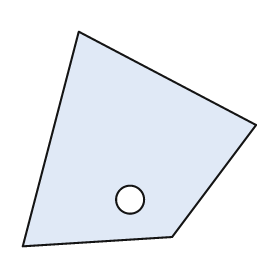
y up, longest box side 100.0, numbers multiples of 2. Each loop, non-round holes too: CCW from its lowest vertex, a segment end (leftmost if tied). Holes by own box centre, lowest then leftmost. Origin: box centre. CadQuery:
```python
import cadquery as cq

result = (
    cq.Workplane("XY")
    .moveTo(-50.0, -46.0)
    .lineTo(14.0, -42.0)
    .lineTo(50.0, 6.0)
    .lineTo(-26.0, 46.0)
    .close()
    .moveTo(-4.0, -26.0)
    .circle(6.0)
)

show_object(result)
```